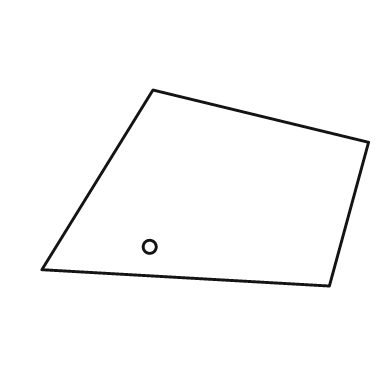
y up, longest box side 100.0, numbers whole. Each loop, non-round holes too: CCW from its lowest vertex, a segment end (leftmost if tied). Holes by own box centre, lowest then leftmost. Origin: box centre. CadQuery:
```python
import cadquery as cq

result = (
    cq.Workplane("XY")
    .moveTo(38.0, -30.0)
    .lineTo(50.0, 14.0)
    .lineTo(-16.0, 30.0)
    .lineTo(-50.0, -25.0)
    .close()
    .moveTo(-17.0, -18.0)
    .circle(2.0)
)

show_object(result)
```